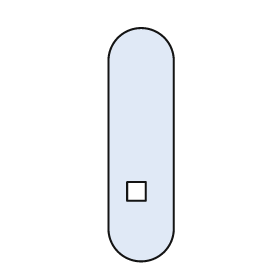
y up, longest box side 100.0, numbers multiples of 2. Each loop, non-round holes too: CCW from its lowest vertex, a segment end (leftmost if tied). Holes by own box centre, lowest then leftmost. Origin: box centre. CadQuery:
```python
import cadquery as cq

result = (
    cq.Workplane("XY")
    .moveTo(-14.0, -36.0)
    .threePointArc((0.0, -50.0), (14.0, -36.0))
    .lineTo(14.0, 36.0)
    .threePointArc((0.0, 50.0), (-14.0, 36.0))
    .close()
    .moveTo(-6.0, -24.0)
    .lineTo(2.0, -24.0)
    .lineTo(2.0, -16.0)
    .lineTo(-6.0, -16.0)
    .close()
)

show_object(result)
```